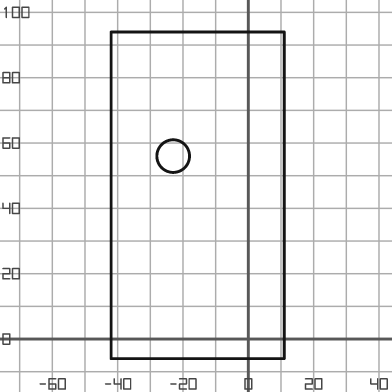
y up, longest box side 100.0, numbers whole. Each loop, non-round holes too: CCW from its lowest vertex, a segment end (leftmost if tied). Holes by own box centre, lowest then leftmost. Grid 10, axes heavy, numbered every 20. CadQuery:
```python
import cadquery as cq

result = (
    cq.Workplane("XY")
    .moveTo(-42.0, -6.0)
    .lineTo(11.0, -6.0)
    .lineTo(11.0, 94.0)
    .lineTo(-42.0, 94.0)
    .close()
    .moveTo(-23.0, 56.0)
    .circle(5.0)
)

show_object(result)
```